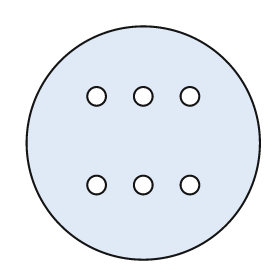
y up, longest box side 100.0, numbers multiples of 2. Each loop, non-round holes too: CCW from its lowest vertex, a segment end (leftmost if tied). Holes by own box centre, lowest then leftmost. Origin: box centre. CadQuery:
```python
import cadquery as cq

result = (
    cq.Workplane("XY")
    .moveTo(0.0, 0.0)
    .circle(50.0)
    .moveTo(-20.0, -18.0)
    .circle(4.0)
    .moveTo(0.0, -18.0)
    .circle(4.0)
    .moveTo(20.0, -18.0)
    .circle(4.0)
    .moveTo(-20.0, 20.0)
    .circle(4.0)
    .moveTo(0.0, 20.0)
    .circle(4.0)
    .moveTo(20.0, 20.0)
    .circle(4.0)
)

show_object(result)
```